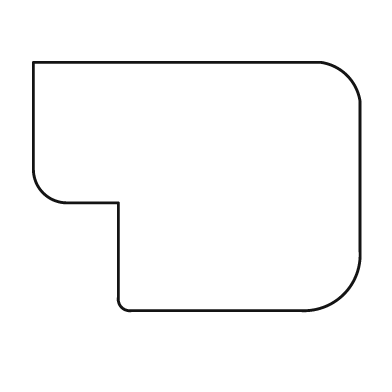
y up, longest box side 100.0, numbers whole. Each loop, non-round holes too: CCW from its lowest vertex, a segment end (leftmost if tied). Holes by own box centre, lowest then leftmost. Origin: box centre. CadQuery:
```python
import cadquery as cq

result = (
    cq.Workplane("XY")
    .moveTo(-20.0, -38.0)
    .lineTo(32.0, -38.0)
    .threePointArc((45.0, -33.0), (50.0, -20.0))
    .lineTo(50.0, 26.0)
    .threePointArc((46.0, 34.0), (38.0, 38.0))
    .lineTo(-50.0, 38.0)
    .lineTo(-50.0, 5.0)
    .threePointArc((-47.0, -2.0), (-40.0, -5.0))
    .lineTo(-24.0, -5.0)
    .lineTo(-24.0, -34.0)
    .threePointArc((-23.0, -37.0), (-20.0, -38.0))
    .close()
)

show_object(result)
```